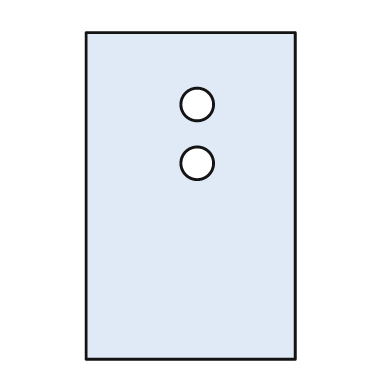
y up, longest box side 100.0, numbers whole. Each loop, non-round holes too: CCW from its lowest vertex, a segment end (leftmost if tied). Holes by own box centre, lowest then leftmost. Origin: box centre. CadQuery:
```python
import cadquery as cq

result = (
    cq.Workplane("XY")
    .moveTo(-32.0, -50.0)
    .lineTo(32.0, -50.0)
    .lineTo(32.0, 50.0)
    .lineTo(-32.0, 50.0)
    .close()
    .moveTo(2.0, 10.0)
    .circle(5.0)
    .moveTo(2.0, 28.0)
    .circle(5.0)
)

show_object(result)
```